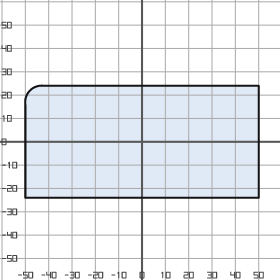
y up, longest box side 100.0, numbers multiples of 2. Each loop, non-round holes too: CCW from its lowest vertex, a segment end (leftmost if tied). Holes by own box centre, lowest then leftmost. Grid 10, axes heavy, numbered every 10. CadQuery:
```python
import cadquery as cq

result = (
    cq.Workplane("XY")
    .moveTo(-50.0, -24.0)
    .lineTo(50.0, -24.0)
    .lineTo(50.0, 24.0)
    .lineTo(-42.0, 24.0)
    .threePointArc((-48.0, 22.0), (-50.0, 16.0))
    .close()
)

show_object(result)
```